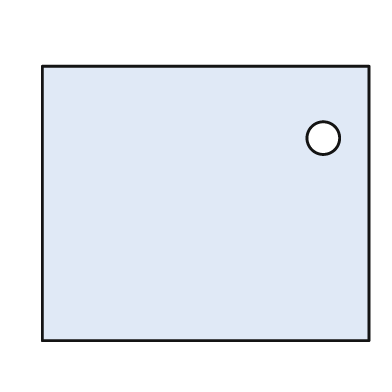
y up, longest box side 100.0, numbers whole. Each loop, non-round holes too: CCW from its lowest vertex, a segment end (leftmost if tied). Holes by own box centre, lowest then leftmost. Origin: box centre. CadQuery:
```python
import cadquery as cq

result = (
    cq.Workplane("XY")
    .moveTo(-50.0, -42.0)
    .lineTo(50.0, -42.0)
    .lineTo(50.0, 42.0)
    .lineTo(-50.0, 42.0)
    .close()
    .moveTo(36.0, 20.0)
    .circle(5.0)
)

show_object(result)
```